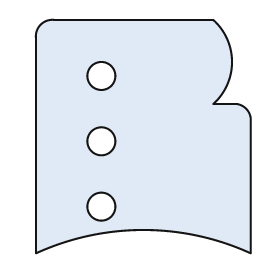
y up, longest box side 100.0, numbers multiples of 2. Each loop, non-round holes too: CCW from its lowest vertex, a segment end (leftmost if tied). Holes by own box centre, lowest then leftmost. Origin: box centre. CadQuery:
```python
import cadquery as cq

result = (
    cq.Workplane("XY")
    .moveTo(-46.0, -50.0)
    .threePointArc((0.0, -40.0), (46.0, -50.0))
    .lineTo(46.0, 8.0)
    .threePointArc((44.0, 12.0), (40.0, 14.0))
    .lineTo(30.0, 14.0)
    .threePointArc((38.0, 32.0), (30.0, 50.0))
    .lineTo(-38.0, 50.0)
    .threePointArc((-44.0, 48.0), (-46.0, 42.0))
    .close()
    .moveTo(-18.0, -30.0)
    .circle(6.0)
    .moveTo(-18.0, -2.0)
    .circle(6.0)
    .moveTo(-18.0, 26.0)
    .circle(6.0)
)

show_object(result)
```